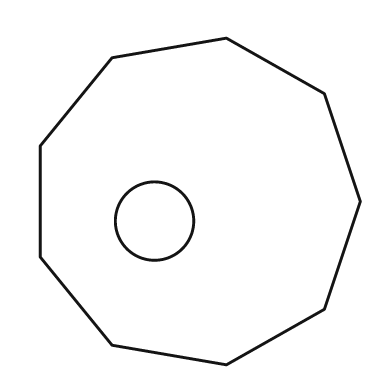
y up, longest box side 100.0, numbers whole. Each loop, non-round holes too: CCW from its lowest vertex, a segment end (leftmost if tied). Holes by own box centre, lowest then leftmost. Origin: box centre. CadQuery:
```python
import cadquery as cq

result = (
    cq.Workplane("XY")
    .moveTo(8.0, -50.0)
    .lineTo(38.0, -33.0)
    .lineTo(49.0, 0.0)
    .lineTo(38.0, 33.0)
    .lineTo(8.0, 50.0)
    .lineTo(-27.0, 44.0)
    .lineTo(-49.0, 17.0)
    .lineTo(-49.0, -17.0)
    .lineTo(-27.0, -44.0)
    .close()
    .moveTo(-14.0, -6.0)
    .circle(12.0)
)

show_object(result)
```